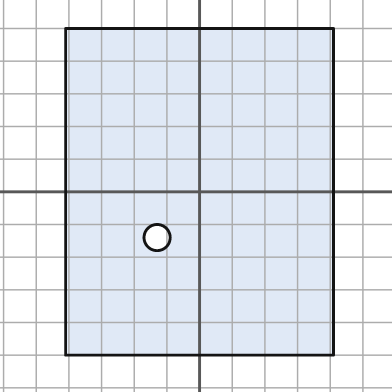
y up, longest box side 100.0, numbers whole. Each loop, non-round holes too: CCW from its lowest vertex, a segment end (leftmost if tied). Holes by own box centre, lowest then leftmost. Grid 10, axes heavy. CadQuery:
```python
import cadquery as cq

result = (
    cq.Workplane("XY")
    .moveTo(-41.0, -50.0)
    .lineTo(41.0, -50.0)
    .lineTo(41.0, 50.0)
    .lineTo(-41.0, 50.0)
    .close()
    .moveTo(-13.0, -14.0)
    .circle(4.0)
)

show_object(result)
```